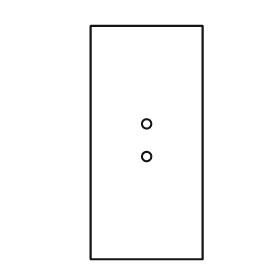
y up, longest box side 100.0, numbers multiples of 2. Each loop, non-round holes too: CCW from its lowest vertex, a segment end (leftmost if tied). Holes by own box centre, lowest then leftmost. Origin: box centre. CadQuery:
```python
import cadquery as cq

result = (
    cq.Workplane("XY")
    .moveTo(-24.0, -50.0)
    .lineTo(24.0, -50.0)
    .lineTo(24.0, 50.0)
    .lineTo(-24.0, 50.0)
    .close()
    .moveTo(0.0, -6.0)
    .circle(2.0)
    .moveTo(0.0, 8.0)
    .circle(2.0)
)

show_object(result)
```